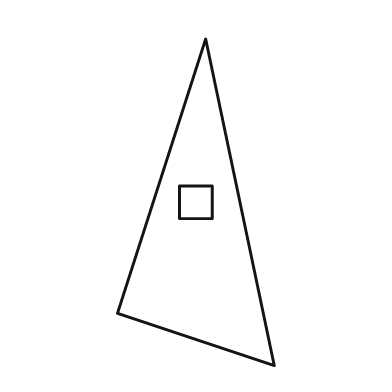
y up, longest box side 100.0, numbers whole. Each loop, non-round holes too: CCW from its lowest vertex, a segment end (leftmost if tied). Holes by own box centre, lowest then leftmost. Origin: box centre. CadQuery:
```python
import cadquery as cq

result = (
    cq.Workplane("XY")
    .moveTo(24.0, -50.0)
    .lineTo(3.0, 50.0)
    .lineTo(-24.0, -34.0)
    .close()
    .moveTo(-5.0, -5.0)
    .lineTo(5.0, -5.0)
    .lineTo(5.0, 5.0)
    .lineTo(-5.0, 5.0)
    .close()
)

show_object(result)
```